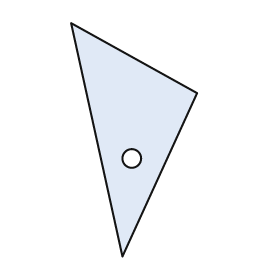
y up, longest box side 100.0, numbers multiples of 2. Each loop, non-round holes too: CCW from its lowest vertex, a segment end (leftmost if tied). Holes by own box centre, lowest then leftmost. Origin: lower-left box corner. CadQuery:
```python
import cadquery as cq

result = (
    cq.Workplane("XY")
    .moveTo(22.0, 0.0)
    .lineTo(54.0, 70.0)
    .lineTo(0.0, 100.0)
    .close()
    .moveTo(26.0, 42.0)
    .circle(4.0)
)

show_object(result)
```